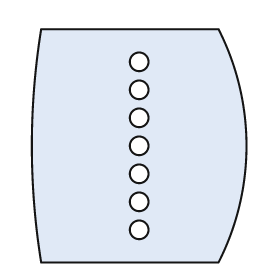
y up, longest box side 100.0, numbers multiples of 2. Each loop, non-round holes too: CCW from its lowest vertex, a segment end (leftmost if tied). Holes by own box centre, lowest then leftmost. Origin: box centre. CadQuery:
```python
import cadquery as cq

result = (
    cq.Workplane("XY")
    .moveTo(-42.0, -50.0)
    .lineTo(34.0, -50.0)
    .threePointArc((46.0, 0.0), (34.0, 50.0))
    .lineTo(-42.0, 50.0)
    .threePointArc((-46.0, 0.0), (-42.0, -50.0))
    .close()
    .moveTo(0.0, -36.0)
    .circle(4.0)
    .moveTo(0.0, -24.0)
    .circle(4.0)
    .moveTo(0.0, -12.0)
    .circle(4.0)
    .moveTo(0.0, 0.0)
    .circle(4.0)
    .moveTo(0.0, 12.0)
    .circle(4.0)
    .moveTo(0.0, 24.0)
    .circle(4.0)
    .moveTo(0.0, 36.0)
    .circle(4.0)
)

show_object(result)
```